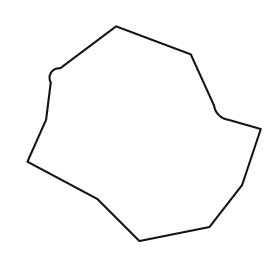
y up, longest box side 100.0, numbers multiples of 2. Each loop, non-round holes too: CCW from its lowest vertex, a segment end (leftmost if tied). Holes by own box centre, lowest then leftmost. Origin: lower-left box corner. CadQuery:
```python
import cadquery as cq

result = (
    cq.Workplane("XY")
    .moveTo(48.0, 0.0)
    .lineTo(78.0, 6.0)
    .lineTo(92.0, 24.0)
    .lineTo(100.0, 48.0)
    .lineTo(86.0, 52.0)
    .threePointArc((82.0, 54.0), (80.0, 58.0))
    .lineTo(70.0, 80.0)
    .lineTo(38.0, 92.0)
    .lineTo(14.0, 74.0)
    .threePointArc((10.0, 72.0), (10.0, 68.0))
    .lineTo(8.0, 52.0)
    .lineTo(0.0, 34.0)
    .lineTo(30.0, 18.0)
    .close()
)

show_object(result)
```